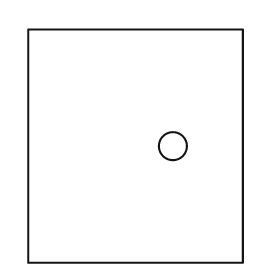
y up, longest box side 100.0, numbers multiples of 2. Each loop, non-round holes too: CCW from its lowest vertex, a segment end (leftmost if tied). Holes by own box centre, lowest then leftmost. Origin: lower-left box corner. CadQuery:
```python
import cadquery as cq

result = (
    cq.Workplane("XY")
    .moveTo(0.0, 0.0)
    .lineTo(92.0, 0.0)
    .lineTo(92.0, 100.0)
    .lineTo(0.0, 100.0)
    .close()
    .moveTo(62.0, 50.0)
    .circle(6.0)
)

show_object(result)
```